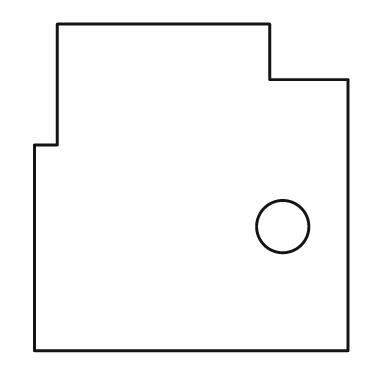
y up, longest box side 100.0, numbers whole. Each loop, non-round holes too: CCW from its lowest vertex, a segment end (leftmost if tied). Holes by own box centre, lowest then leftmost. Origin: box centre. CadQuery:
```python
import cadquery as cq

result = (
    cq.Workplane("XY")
    .moveTo(-48.0, -50.0)
    .lineTo(48.0, -50.0)
    .lineTo(48.0, 33.0)
    .lineTo(24.0, 33.0)
    .lineTo(24.0, 50.0)
    .lineTo(-41.0, 50.0)
    .lineTo(-41.0, 13.0)
    .lineTo(-48.0, 13.0)
    .close()
    .moveTo(28.0, -12.0)
    .circle(8.0)
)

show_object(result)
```